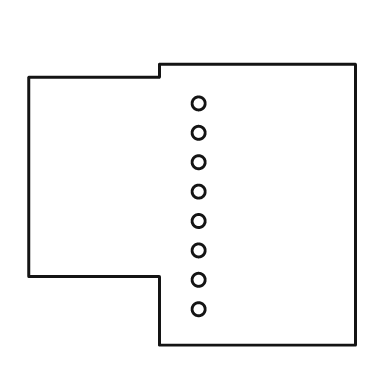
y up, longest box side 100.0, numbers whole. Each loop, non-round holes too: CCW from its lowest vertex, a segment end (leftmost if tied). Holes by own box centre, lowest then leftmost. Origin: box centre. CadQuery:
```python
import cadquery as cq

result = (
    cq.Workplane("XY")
    .moveTo(-10.0, -43.0)
    .lineTo(50.0, -43.0)
    .lineTo(50.0, 43.0)
    .lineTo(-10.0, 43.0)
    .lineTo(-10.0, 39.0)
    .lineTo(-50.0, 39.0)
    .lineTo(-50.0, -22.0)
    .lineTo(-10.0, -22.0)
    .close()
    .moveTo(2.0, -32.0)
    .circle(2.0)
    .moveTo(2.0, -23.0)
    .circle(2.0)
    .moveTo(2.0, -14.0)
    .circle(2.0)
    .moveTo(2.0, -5.0)
    .circle(2.0)
    .moveTo(2.0, 4.0)
    .circle(2.0)
    .moveTo(2.0, 13.0)
    .circle(2.0)
    .moveTo(2.0, 22.0)
    .circle(2.0)
    .moveTo(2.0, 31.0)
    .circle(2.0)
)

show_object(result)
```